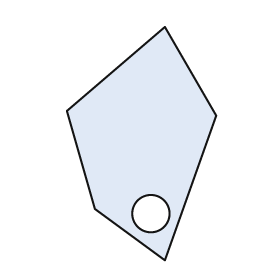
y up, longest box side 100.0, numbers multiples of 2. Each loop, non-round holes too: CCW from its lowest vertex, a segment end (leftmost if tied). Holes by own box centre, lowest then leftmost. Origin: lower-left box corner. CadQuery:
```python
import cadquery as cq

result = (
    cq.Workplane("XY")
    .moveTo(42.0, 0.0)
    .lineTo(64.0, 62.0)
    .lineTo(42.0, 100.0)
    .lineTo(0.0, 64.0)
    .lineTo(12.0, 22.0)
    .close()
    .moveTo(36.0, 20.0)
    .circle(8.0)
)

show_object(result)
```